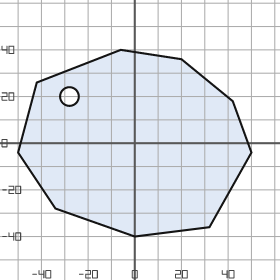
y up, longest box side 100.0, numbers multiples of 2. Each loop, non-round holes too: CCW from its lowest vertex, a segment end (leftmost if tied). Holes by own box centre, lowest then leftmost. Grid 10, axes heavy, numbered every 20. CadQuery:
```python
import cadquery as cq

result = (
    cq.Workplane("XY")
    .moveTo(0.0, -40.0)
    .lineTo(32.0, -36.0)
    .lineTo(50.0, -4.0)
    .lineTo(42.0, 18.0)
    .lineTo(20.0, 36.0)
    .lineTo(-6.0, 40.0)
    .lineTo(-42.0, 26.0)
    .lineTo(-50.0, -4.0)
    .lineTo(-34.0, -28.0)
    .close()
    .moveTo(-28.0, 20.0)
    .circle(4.0)
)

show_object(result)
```